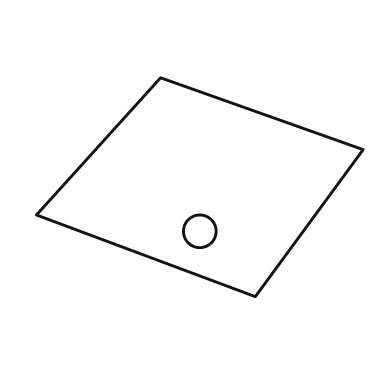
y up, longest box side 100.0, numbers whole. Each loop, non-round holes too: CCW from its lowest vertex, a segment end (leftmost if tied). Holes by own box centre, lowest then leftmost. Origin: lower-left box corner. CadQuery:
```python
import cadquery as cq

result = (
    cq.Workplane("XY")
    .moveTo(67.0, 0.0)
    .lineTo(100.0, 45.0)
    .lineTo(38.0, 67.0)
    .lineTo(0.0, 25.0)
    .close()
    .moveTo(50.0, 20.0)
    .circle(5.0)
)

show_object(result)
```